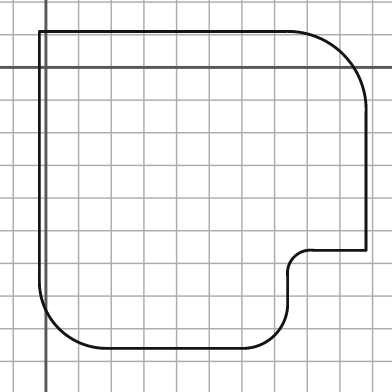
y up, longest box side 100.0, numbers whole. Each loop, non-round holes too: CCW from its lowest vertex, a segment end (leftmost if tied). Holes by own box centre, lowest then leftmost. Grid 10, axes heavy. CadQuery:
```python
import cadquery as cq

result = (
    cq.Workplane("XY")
    .moveTo(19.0, -86.0)
    .lineTo(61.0, -86.0)
    .threePointArc((70.0, -82.0), (74.0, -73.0))
    .lineTo(74.0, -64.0)
    .threePointArc((76.0, -58.0), (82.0, -56.0))
    .lineTo(98.0, -56.0)
    .lineTo(98.0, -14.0)
    .threePointArc((91.0, 4.0), (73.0, 11.0))
    .lineTo(-2.0, 11.0)
    .lineTo(-2.0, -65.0)
    .threePointArc((4.0, -80.0), (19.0, -86.0))
    .close()
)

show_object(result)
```